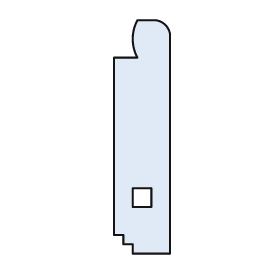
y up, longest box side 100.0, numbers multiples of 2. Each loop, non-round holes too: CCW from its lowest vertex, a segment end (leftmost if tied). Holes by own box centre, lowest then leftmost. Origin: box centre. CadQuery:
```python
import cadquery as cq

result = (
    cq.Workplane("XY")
    .moveTo(-4.0, -50.0)
    .lineTo(12.0, -50.0)
    .lineTo(12.0, 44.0)
    .threePointArc((10.0, 48.0), (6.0, 50.0))
    .lineTo(-2.0, 50.0)
    .threePointArc((-4.0, 42.0), (-2.0, 34.0))
    .lineTo(-12.0, 34.0)
    .lineTo(-12.0, -42.0)
    .lineTo(-8.0, -42.0)
    .lineTo(-8.0, -46.0)
    .lineTo(-4.0, -46.0)
    .close()
    .moveTo(-4.0, -30.0)
    .lineTo(4.0, -30.0)
    .lineTo(4.0, -22.0)
    .lineTo(-4.0, -22.0)
    .close()
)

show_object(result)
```